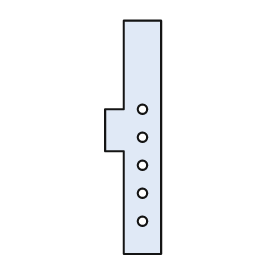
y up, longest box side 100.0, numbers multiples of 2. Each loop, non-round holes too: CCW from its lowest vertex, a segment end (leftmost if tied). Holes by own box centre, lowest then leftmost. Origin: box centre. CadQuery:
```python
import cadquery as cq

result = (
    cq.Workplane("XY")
    .moveTo(-4.0, -50.0)
    .lineTo(12.0, -50.0)
    .lineTo(12.0, 50.0)
    .lineTo(-4.0, 50.0)
    .lineTo(-4.0, 12.0)
    .lineTo(-12.0, 12.0)
    .lineTo(-12.0, -6.0)
    .lineTo(-4.0, -6.0)
    .close()
    .moveTo(4.0, -36.0)
    .circle(2.0)
    .moveTo(4.0, -24.0)
    .circle(2.0)
    .moveTo(4.0, -12.0)
    .circle(2.0)
    .moveTo(4.0, 0.0)
    .circle(2.0)
    .moveTo(4.0, 12.0)
    .circle(2.0)
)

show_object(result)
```